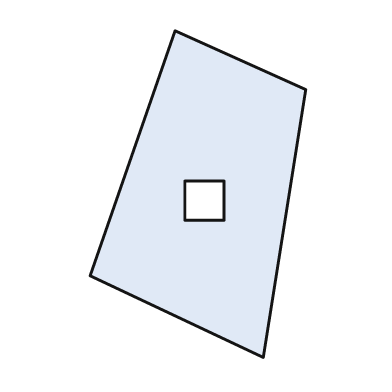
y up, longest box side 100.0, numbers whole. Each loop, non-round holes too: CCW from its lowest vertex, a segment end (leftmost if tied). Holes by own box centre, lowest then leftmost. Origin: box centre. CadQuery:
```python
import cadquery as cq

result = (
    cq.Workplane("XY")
    .moveTo(20.0, -50.0)
    .lineTo(33.0, 32.0)
    .lineTo(-7.0, 50.0)
    .lineTo(-33.0, -25.0)
    .close()
    .moveTo(-4.0, -8.0)
    .lineTo(8.0, -8.0)
    .lineTo(8.0, 4.0)
    .lineTo(-4.0, 4.0)
    .close()
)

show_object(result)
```